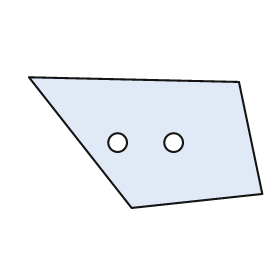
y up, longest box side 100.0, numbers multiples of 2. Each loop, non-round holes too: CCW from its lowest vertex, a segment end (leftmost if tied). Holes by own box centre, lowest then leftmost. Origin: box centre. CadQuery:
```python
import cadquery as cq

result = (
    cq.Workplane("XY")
    .moveTo(-6.0, -28.0)
    .lineTo(50.0, -22.0)
    .lineTo(40.0, 26.0)
    .lineTo(-50.0, 28.0)
    .close()
    .moveTo(-12.0, 0.0)
    .circle(4.0)
    .moveTo(12.0, 0.0)
    .circle(4.0)
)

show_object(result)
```